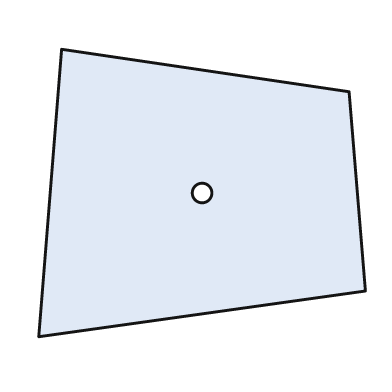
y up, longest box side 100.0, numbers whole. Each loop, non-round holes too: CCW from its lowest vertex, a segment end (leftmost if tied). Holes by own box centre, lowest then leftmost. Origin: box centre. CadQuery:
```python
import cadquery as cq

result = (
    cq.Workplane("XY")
    .moveTo(-50.0, -44.0)
    .lineTo(50.0, -30.0)
    .lineTo(45.0, 31.0)
    .lineTo(-43.0, 44.0)
    .close()
    .moveTo(0.0, 0.0)
    .circle(3.0)
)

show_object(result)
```